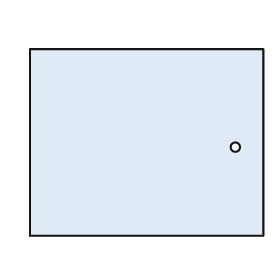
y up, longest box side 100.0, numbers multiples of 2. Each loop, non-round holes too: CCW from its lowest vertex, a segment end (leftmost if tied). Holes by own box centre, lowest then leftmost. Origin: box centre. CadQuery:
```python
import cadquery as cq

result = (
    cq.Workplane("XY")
    .moveTo(-50.0, -40.0)
    .lineTo(50.0, -40.0)
    .lineTo(50.0, 40.0)
    .lineTo(-50.0, 40.0)
    .close()
    .moveTo(38.0, -2.0)
    .circle(2.0)
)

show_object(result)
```